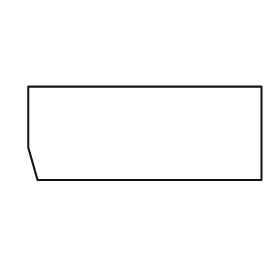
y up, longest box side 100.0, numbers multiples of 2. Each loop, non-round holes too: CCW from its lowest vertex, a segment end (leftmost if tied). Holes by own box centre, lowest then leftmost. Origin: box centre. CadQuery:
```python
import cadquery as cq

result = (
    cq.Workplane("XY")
    .moveTo(-46.0, -20.0)
    .lineTo(50.0, -20.0)
    .lineTo(50.0, 20.0)
    .lineTo(-50.0, 20.0)
    .lineTo(-50.0, -6.0)
    .close()
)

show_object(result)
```